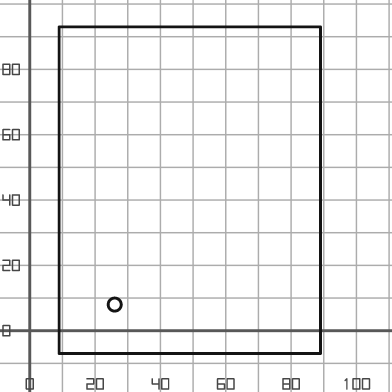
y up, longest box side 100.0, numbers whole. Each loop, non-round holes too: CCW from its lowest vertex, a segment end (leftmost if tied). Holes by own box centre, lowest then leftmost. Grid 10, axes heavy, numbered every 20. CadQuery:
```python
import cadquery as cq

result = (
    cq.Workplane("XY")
    .moveTo(9.0, -7.0)
    .lineTo(89.0, -7.0)
    .lineTo(89.0, 93.0)
    .lineTo(9.0, 93.0)
    .close()
    .moveTo(26.0, 8.0)
    .circle(2.0)
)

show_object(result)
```